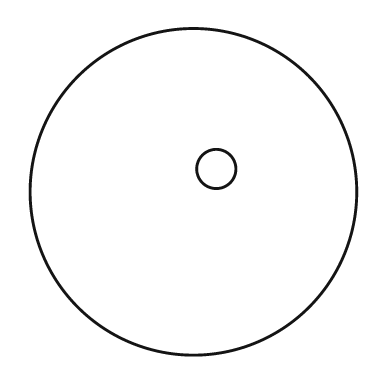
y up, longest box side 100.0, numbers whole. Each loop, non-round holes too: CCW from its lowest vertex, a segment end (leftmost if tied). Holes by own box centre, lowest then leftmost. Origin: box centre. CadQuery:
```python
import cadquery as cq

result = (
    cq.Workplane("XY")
    .moveTo(0.0, 0.0)
    .circle(50.0)
    .moveTo(7.0, 7.0)
    .circle(6.0)
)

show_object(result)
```